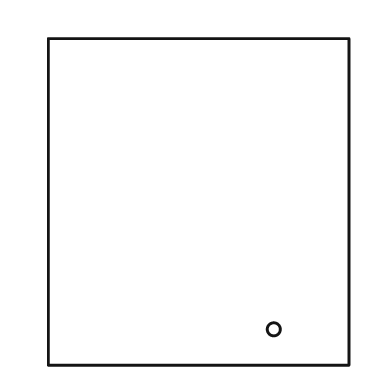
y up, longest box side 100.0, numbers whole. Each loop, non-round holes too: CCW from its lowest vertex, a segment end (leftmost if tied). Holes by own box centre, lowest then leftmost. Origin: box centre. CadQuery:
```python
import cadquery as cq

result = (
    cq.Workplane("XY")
    .moveTo(-46.0, -50.0)
    .lineTo(46.0, -50.0)
    .lineTo(46.0, 50.0)
    .lineTo(-46.0, 50.0)
    .close()
    .moveTo(23.0, -39.0)
    .circle(2.0)
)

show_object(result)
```